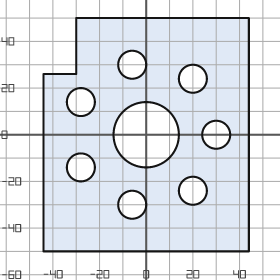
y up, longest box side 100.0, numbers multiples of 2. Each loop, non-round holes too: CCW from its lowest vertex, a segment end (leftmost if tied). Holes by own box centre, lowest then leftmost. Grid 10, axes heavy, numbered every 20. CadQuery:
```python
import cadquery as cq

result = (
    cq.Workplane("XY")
    .moveTo(-44.0, -50.0)
    .lineTo(44.0, -50.0)
    .lineTo(44.0, 50.0)
    .lineTo(-30.0, 50.0)
    .lineTo(-30.0, 26.0)
    .lineTo(-44.0, 26.0)
    .close()
    .moveTo(-6.0, -30.0)
    .circle(6.0)
    .moveTo(20.0, -24.0)
    .circle(6.0)
    .moveTo(-28.0, -14.0)
    .circle(6.0)
    .moveTo(0.0, 0.0)
    .circle(14.0)
    .moveTo(30.0, 0.0)
    .circle(6.0)
    .moveTo(-28.0, 14.0)
    .circle(6.0)
    .moveTo(20.0, 24.0)
    .circle(6.0)
    .moveTo(-6.0, 30.0)
    .circle(6.0)
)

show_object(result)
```